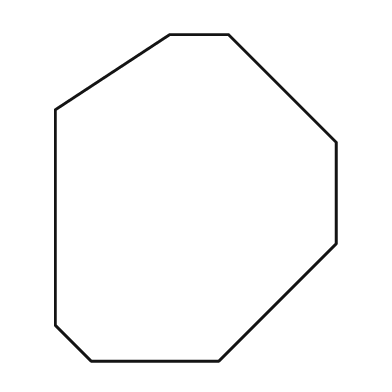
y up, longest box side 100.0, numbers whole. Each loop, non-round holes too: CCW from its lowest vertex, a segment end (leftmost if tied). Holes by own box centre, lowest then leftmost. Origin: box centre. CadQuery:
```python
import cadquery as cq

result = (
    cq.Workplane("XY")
    .moveTo(-32.0, -50.0)
    .lineTo(7.0, -50.0)
    .lineTo(43.0, -14.0)
    .lineTo(43.0, 17.0)
    .lineTo(10.0, 50.0)
    .lineTo(-8.0, 50.0)
    .lineTo(-43.0, 27.0)
    .lineTo(-43.0, -39.0)
    .close()
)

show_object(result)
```